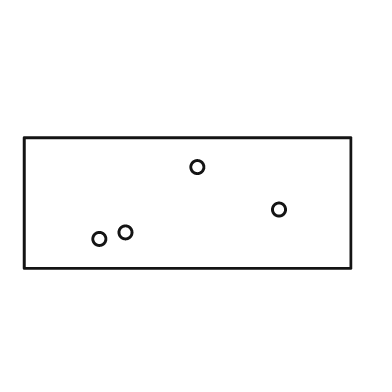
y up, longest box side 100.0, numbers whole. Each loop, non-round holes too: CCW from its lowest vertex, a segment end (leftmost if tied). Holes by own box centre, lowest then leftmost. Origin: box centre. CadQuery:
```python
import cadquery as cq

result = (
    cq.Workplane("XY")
    .moveTo(-50.0, -20.0)
    .lineTo(50.0, -20.0)
    .lineTo(50.0, 20.0)
    .lineTo(-50.0, 20.0)
    .close()
    .moveTo(-27.0, -11.0)
    .circle(2.0)
    .moveTo(-19.0, -9.0)
    .circle(2.0)
    .moveTo(28.0, -2.0)
    .circle(2.0)
    .moveTo(3.0, 11.0)
    .circle(2.0)
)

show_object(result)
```